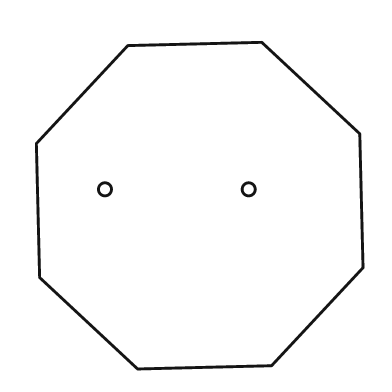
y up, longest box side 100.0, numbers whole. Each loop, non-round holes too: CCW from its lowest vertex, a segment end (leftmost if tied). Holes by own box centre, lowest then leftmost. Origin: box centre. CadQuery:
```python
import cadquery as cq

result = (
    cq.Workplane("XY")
    .moveTo(-19.0, -50.0)
    .lineTo(22.0, -49.0)
    .lineTo(50.0, -19.0)
    .lineTo(49.0, 22.0)
    .lineTo(19.0, 50.0)
    .lineTo(-22.0, 49.0)
    .lineTo(-50.0, 19.0)
    .lineTo(-49.0, -22.0)
    .close()
    .moveTo(-29.0, 5.0)
    .circle(2.0)
    .moveTo(15.0, 5.0)
    .circle(2.0)
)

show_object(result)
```